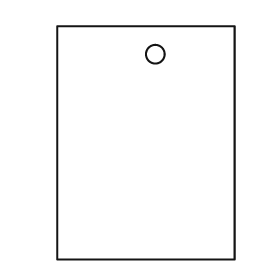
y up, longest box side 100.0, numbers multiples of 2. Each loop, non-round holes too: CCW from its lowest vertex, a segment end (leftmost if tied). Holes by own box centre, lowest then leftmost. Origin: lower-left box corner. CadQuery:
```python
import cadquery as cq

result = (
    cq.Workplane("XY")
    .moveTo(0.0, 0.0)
    .lineTo(76.0, 0.0)
    .lineTo(76.0, 100.0)
    .lineTo(0.0, 100.0)
    .close()
    .moveTo(42.0, 88.0)
    .circle(4.0)
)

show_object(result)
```